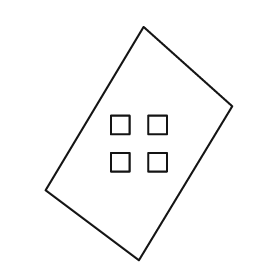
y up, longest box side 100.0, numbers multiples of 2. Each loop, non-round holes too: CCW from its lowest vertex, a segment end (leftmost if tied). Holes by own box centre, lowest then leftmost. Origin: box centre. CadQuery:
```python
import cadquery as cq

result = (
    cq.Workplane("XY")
    .moveTo(0.0, -50.0)
    .lineTo(40.0, 16.0)
    .lineTo(2.0, 50.0)
    .lineTo(-40.0, -20.0)
    .close()
    .moveTo(-12.0, -12.0)
    .lineTo(-4.0, -12.0)
    .lineTo(-4.0, -4.0)
    .lineTo(-12.0, -4.0)
    .close()
    .moveTo(4.0, -12.0)
    .lineTo(12.0, -12.0)
    .lineTo(12.0, -4.0)
    .lineTo(4.0, -4.0)
    .close()
    .moveTo(-12.0, 4.0)
    .lineTo(-4.0, 4.0)
    .lineTo(-4.0, 12.0)
    .lineTo(-12.0, 12.0)
    .close()
    .moveTo(4.0, 4.0)
    .lineTo(12.0, 4.0)
    .lineTo(12.0, 12.0)
    .lineTo(4.0, 12.0)
    .close()
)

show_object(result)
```